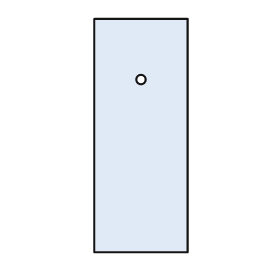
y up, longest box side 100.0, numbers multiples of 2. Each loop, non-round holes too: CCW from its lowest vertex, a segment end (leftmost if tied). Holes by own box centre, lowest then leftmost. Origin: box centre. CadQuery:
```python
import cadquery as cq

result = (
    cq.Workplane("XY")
    .moveTo(-20.0, -50.0)
    .lineTo(20.0, -50.0)
    .lineTo(20.0, 50.0)
    .lineTo(-20.0, 50.0)
    .close()
    .moveTo(0.0, 24.0)
    .circle(2.0)
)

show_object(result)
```